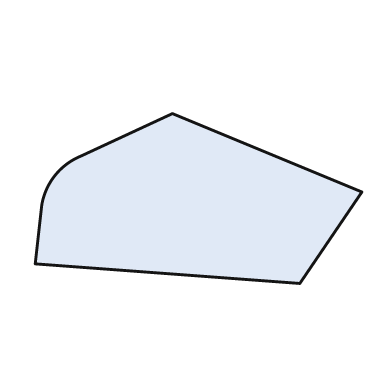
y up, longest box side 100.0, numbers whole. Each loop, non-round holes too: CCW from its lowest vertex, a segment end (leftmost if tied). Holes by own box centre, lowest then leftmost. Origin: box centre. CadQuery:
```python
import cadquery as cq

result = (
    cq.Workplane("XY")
    .moveTo(31.0, -26.0)
    .lineTo(50.0, 2.0)
    .lineTo(-8.0, 26.0)
    .lineTo(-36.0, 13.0)
    .threePointArc((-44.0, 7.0), (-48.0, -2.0))
    .lineTo(-50.0, -20.0)
    .close()
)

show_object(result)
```